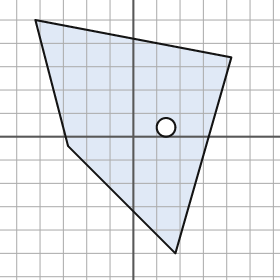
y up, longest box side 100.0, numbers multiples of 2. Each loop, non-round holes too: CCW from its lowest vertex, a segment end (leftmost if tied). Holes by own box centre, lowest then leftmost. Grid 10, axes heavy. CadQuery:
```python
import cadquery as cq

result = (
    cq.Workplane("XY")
    .moveTo(18.0, -50.0)
    .lineTo(42.0, 34.0)
    .lineTo(-42.0, 50.0)
    .lineTo(-28.0, -4.0)
    .close()
    .moveTo(14.0, 4.0)
    .circle(4.0)
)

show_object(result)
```